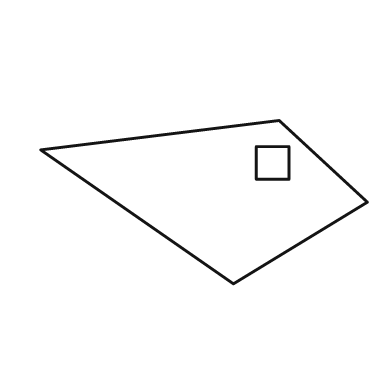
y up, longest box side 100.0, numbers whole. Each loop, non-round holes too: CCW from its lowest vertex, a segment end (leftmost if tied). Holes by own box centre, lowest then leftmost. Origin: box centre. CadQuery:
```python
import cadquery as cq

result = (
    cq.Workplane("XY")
    .moveTo(9.0, -25.0)
    .lineTo(50.0, 0.0)
    .lineTo(23.0, 25.0)
    .lineTo(-50.0, 16.0)
    .close()
    .moveTo(16.0, 7.0)
    .lineTo(26.0, 7.0)
    .lineTo(26.0, 17.0)
    .lineTo(16.0, 17.0)
    .close()
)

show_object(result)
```